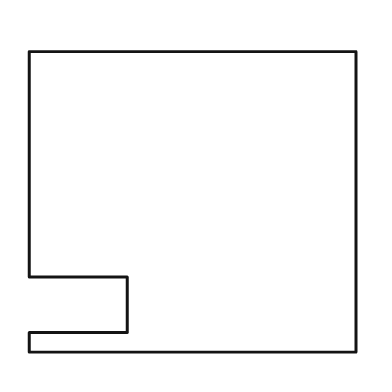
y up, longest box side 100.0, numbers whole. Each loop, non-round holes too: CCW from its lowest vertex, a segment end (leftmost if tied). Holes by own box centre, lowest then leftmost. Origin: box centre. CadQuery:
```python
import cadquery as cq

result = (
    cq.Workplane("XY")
    .moveTo(-50.0, -46.0)
    .lineTo(50.0, -46.0)
    .lineTo(50.0, 46.0)
    .lineTo(-50.0, 46.0)
    .lineTo(-50.0, -23.0)
    .lineTo(-20.0, -23.0)
    .lineTo(-20.0, -40.0)
    .lineTo(-50.0, -40.0)
    .close()
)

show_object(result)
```